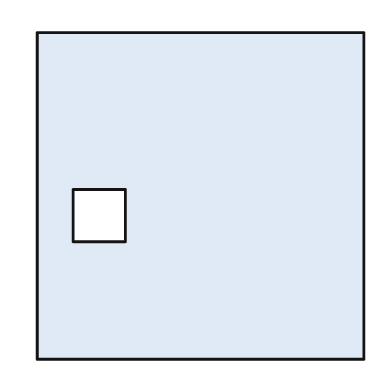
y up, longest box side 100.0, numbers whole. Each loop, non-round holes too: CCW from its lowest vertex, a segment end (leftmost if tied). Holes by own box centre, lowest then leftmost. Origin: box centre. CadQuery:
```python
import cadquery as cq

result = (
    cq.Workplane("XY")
    .moveTo(-50.0, -50.0)
    .lineTo(50.0, -50.0)
    .lineTo(50.0, 50.0)
    .lineTo(-50.0, 50.0)
    .close()
    .moveTo(-39.0, -14.0)
    .lineTo(-23.0, -14.0)
    .lineTo(-23.0, 2.0)
    .lineTo(-39.0, 2.0)
    .close()
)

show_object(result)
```